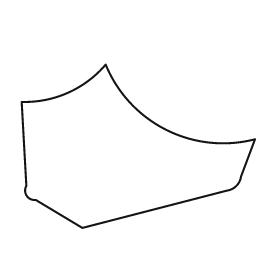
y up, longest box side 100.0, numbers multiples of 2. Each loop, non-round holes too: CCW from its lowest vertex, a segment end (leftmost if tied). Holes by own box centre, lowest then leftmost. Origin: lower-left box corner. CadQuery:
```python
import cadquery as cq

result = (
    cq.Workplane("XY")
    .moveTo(26.0, 0.0)
    .lineTo(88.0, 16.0)
    .threePointArc((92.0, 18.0), (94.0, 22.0))
    .lineTo(100.0, 38.0)
    .threePointArc((62.0, 42.0), (36.0, 70.0))
    .threePointArc((20.0, 58.0), (0.0, 54.0))
    .lineTo(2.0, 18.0)
    .threePointArc((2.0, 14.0), (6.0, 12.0))
    .close()
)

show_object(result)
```